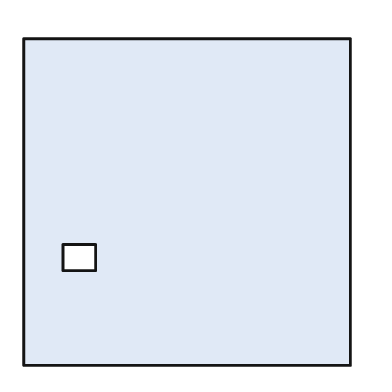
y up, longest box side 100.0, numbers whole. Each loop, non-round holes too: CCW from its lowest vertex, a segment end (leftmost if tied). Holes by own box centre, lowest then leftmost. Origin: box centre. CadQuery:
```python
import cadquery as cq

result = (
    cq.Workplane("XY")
    .moveTo(-50.0, -50.0)
    .lineTo(50.0, -50.0)
    .lineTo(50.0, 50.0)
    .lineTo(-50.0, 50.0)
    .close()
    .moveTo(-38.0, -21.0)
    .lineTo(-28.0, -21.0)
    .lineTo(-28.0, -13.0)
    .lineTo(-38.0, -13.0)
    .close()
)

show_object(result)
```